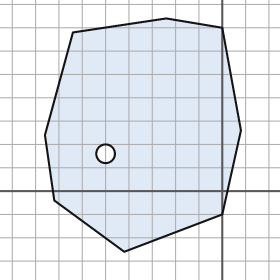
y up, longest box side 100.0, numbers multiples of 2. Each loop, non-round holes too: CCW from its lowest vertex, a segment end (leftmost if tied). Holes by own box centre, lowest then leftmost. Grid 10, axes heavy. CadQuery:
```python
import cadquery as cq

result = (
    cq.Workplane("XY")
    .moveTo(-42.0, -26.0)
    .lineTo(0.0, -10.0)
    .lineTo(8.0, 26.0)
    .lineTo(0.0, 70.0)
    .lineTo(-24.0, 74.0)
    .lineTo(-64.0, 68.0)
    .lineTo(-76.0, 24.0)
    .lineTo(-72.0, -4.0)
    .close()
    .moveTo(-50.0, 16.0)
    .circle(4.0)
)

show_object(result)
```